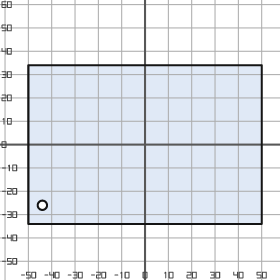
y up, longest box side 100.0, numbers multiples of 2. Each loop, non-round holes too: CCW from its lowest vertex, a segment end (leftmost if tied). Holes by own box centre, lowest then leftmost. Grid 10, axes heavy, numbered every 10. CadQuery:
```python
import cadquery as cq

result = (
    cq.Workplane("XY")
    .moveTo(-50.0, -34.0)
    .lineTo(50.0, -34.0)
    .lineTo(50.0, 34.0)
    .lineTo(-50.0, 34.0)
    .close()
    .moveTo(-44.0, -26.0)
    .circle(2.0)
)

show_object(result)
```